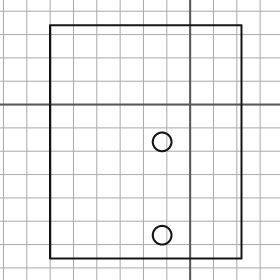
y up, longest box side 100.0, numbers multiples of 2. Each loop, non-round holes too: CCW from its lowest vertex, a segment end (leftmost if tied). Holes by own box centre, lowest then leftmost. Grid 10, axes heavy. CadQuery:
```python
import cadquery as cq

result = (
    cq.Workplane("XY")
    .moveTo(-60.0, -66.0)
    .lineTo(22.0, -66.0)
    .lineTo(22.0, 34.0)
    .lineTo(-60.0, 34.0)
    .close()
    .moveTo(-12.0, -56.0)
    .circle(4.0)
    .moveTo(-12.0, -16.0)
    .circle(4.0)
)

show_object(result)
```